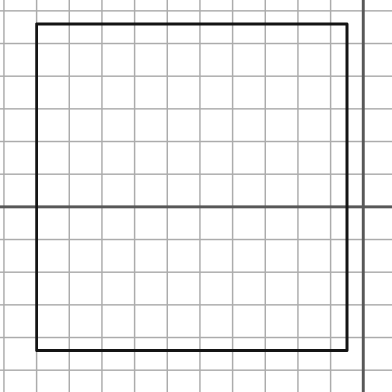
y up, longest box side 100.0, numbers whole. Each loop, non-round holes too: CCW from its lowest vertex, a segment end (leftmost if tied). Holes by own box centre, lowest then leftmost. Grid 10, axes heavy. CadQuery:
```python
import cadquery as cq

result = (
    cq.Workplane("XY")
    .moveTo(-100.0, -44.0)
    .lineTo(-5.0, -44.0)
    .lineTo(-5.0, 56.0)
    .lineTo(-100.0, 56.0)
    .close()
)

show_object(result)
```